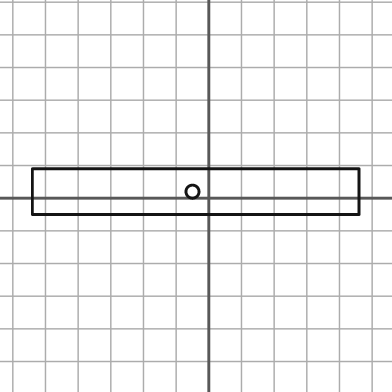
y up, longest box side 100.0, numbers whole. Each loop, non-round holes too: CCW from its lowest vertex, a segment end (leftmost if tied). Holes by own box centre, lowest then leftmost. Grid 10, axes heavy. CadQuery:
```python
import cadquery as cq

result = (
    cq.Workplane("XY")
    .moveTo(-54.0, -5.0)
    .lineTo(46.0, -5.0)
    .lineTo(46.0, 9.0)
    .lineTo(-54.0, 9.0)
    .close()
    .moveTo(-5.0, 2.0)
    .circle(2.0)
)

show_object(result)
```